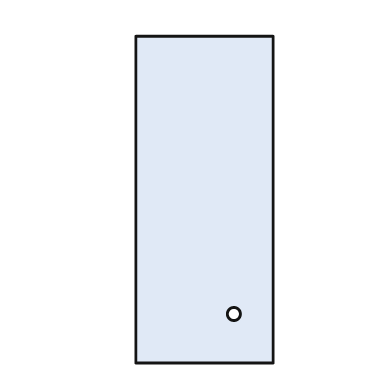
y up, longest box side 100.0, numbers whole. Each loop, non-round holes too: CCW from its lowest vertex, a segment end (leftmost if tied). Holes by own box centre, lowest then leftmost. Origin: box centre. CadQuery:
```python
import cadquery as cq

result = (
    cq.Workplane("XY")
    .moveTo(-21.0, -50.0)
    .lineTo(21.0, -50.0)
    .lineTo(21.0, 50.0)
    .lineTo(-21.0, 50.0)
    .close()
    .moveTo(9.0, -35.0)
    .circle(2.0)
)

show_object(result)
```